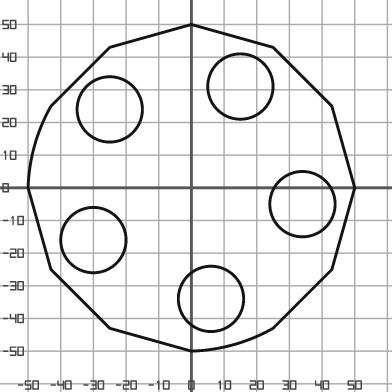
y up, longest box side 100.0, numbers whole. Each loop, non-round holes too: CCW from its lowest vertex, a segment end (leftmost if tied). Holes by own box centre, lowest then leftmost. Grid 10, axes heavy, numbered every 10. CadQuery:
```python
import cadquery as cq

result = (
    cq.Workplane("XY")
    .moveTo(0.0, -50.0)
    .threePointArc((13.0, -48.0), (25.0, -43.0))
    .lineTo(43.0, -25.0)
    .lineTo(50.0, 0.0)
    .lineTo(43.0, 25.0)
    .lineTo(25.0, 43.0)
    .lineTo(0.0, 50.0)
    .lineTo(-25.0, 43.0)
    .lineTo(-43.0, 25.0)
    .threePointArc((-48.0, 13.0), (-50.0, 0.0))
    .lineTo(-43.0, -25.0)
    .lineTo(-25.0, -43.0)
    .close()
    .moveTo(6.0, -34.0)
    .circle(10.0)
    .moveTo(-30.0, -16.0)
    .circle(10.0)
    .moveTo(34.0, -5.0)
    .circle(10.0)
    .moveTo(-25.0, 24.0)
    .circle(10.0)
    .moveTo(15.0, 31.0)
    .circle(10.0)
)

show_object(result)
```